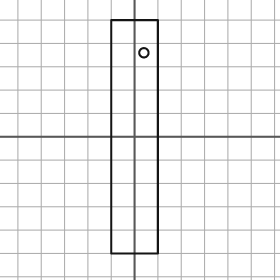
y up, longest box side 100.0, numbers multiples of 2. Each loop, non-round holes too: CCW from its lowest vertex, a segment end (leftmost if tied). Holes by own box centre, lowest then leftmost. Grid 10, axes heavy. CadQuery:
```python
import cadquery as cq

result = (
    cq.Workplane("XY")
    .moveTo(-10.0, -50.0)
    .lineTo(10.0, -50.0)
    .lineTo(10.0, 50.0)
    .lineTo(-10.0, 50.0)
    .close()
    .moveTo(4.0, 36.0)
    .circle(2.0)
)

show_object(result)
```